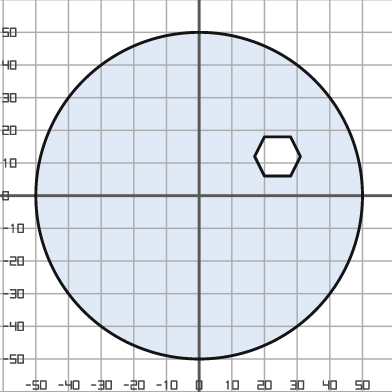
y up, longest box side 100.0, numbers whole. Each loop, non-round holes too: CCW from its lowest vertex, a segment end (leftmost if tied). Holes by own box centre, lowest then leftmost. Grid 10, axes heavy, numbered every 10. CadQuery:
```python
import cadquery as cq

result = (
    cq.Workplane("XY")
    .moveTo(0.0, 0.0)
    .circle(50.0)
    .moveTo(20.0, 6.0)
    .lineTo(28.0, 6.0)
    .lineTo(31.0, 12.0)
    .lineTo(28.0, 18.0)
    .lineTo(20.0, 18.0)
    .lineTo(17.0, 12.0)
    .close()
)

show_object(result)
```